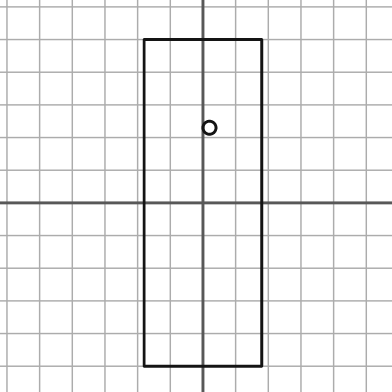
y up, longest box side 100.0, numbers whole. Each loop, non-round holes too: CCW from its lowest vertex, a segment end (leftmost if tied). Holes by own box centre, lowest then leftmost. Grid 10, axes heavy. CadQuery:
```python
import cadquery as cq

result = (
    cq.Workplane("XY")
    .moveTo(-18.0, -50.0)
    .lineTo(18.0, -50.0)
    .lineTo(18.0, 50.0)
    .lineTo(-18.0, 50.0)
    .close()
    .moveTo(2.0, 23.0)
    .circle(2.0)
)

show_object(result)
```